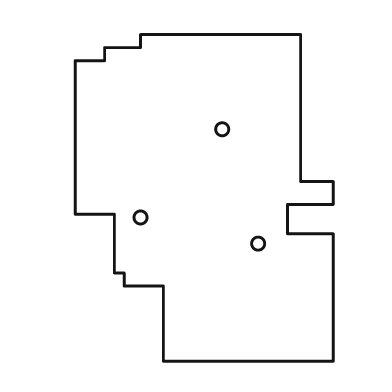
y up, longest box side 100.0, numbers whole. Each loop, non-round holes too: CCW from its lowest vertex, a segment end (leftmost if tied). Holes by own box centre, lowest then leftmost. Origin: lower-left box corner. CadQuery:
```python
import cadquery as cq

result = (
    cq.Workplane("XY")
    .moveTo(27.0, 0.0)
    .lineTo(79.0, 0.0)
    .lineTo(79.0, 39.0)
    .lineTo(65.0, 39.0)
    .lineTo(65.0, 48.0)
    .lineTo(79.0, 48.0)
    .lineTo(79.0, 55.0)
    .lineTo(69.0, 55.0)
    .lineTo(69.0, 100.0)
    .lineTo(20.0, 100.0)
    .lineTo(20.0, 96.0)
    .lineTo(9.0, 96.0)
    .lineTo(9.0, 92.0)
    .lineTo(0.0, 92.0)
    .lineTo(0.0, 45.0)
    .lineTo(12.0, 45.0)
    .lineTo(12.0, 27.0)
    .lineTo(15.0, 27.0)
    .lineTo(15.0, 23.0)
    .lineTo(27.0, 23.0)
    .close()
    .moveTo(56.0, 36.0)
    .circle(2.0)
    .moveTo(20.0, 44.0)
    .circle(2.0)
    .moveTo(45.0, 71.0)
    .circle(2.0)
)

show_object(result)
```